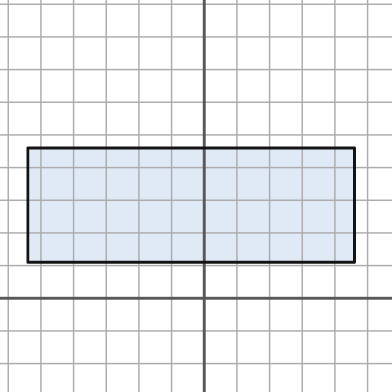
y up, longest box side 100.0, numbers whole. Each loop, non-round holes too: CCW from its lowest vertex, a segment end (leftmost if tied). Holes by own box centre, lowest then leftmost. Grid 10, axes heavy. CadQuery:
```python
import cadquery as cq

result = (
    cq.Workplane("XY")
    .moveTo(-54.0, 11.0)
    .lineTo(46.0, 11.0)
    .lineTo(46.0, 46.0)
    .lineTo(-54.0, 46.0)
    .close()
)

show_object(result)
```